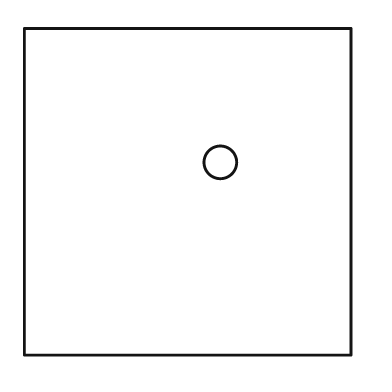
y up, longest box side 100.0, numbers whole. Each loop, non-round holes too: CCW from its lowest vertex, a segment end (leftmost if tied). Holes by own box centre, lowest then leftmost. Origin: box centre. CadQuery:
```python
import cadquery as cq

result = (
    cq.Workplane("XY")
    .moveTo(-50.0, -50.0)
    .lineTo(50.0, -50.0)
    .lineTo(50.0, 50.0)
    .lineTo(-50.0, 50.0)
    .close()
    .moveTo(10.0, 9.0)
    .circle(5.0)
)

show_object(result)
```